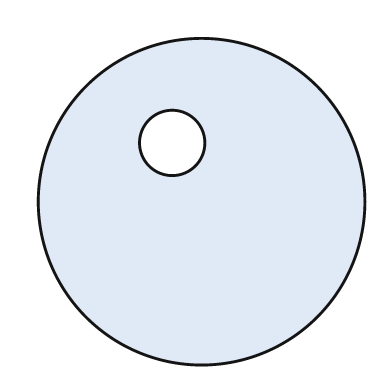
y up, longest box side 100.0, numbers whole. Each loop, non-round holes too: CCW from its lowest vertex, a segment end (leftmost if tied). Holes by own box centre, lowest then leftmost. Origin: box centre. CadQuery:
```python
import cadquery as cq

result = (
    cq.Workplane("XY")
    .moveTo(0.0, 0.0)
    .circle(50.0)
    .moveTo(-9.0, 18.0)
    .circle(10.0)
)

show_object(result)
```